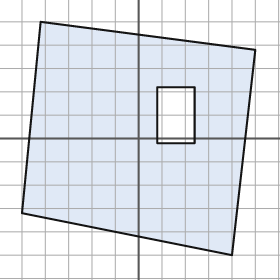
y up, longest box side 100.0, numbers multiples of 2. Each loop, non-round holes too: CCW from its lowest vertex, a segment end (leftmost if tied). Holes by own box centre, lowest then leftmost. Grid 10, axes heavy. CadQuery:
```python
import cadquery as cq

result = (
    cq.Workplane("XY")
    .moveTo(40.0, -50.0)
    .lineTo(50.0, 38.0)
    .lineTo(-42.0, 50.0)
    .lineTo(-50.0, -32.0)
    .close()
    .moveTo(8.0, -2.0)
    .lineTo(24.0, -2.0)
    .lineTo(24.0, 22.0)
    .lineTo(8.0, 22.0)
    .close()
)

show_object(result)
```